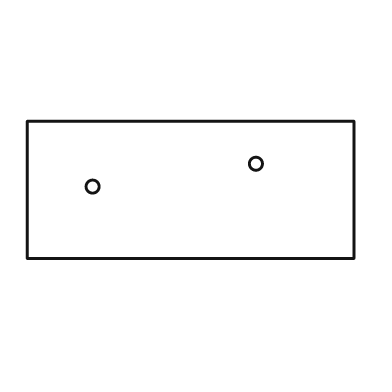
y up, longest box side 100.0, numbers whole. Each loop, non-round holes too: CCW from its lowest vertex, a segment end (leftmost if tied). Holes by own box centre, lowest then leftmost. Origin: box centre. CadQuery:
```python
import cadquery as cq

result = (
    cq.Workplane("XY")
    .moveTo(-50.0, -21.0)
    .lineTo(50.0, -21.0)
    .lineTo(50.0, 21.0)
    .lineTo(-50.0, 21.0)
    .close()
    .moveTo(-30.0, 1.0)
    .circle(2.0)
    .moveTo(20.0, 8.0)
    .circle(2.0)
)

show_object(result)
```